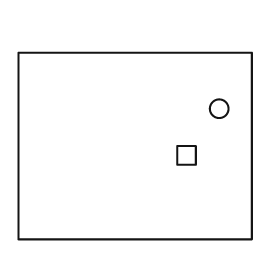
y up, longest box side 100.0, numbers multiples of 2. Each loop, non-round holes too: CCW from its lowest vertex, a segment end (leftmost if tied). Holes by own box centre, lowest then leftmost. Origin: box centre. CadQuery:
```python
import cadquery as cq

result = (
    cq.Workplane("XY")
    .moveTo(-50.0, -40.0)
    .lineTo(50.0, -40.0)
    .lineTo(50.0, 40.0)
    .lineTo(-50.0, 40.0)
    .close()
    .moveTo(18.0, -8.0)
    .lineTo(26.0, -8.0)
    .lineTo(26.0, 0.0)
    .lineTo(18.0, 0.0)
    .close()
    .moveTo(36.0, 16.0)
    .circle(4.0)
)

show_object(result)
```